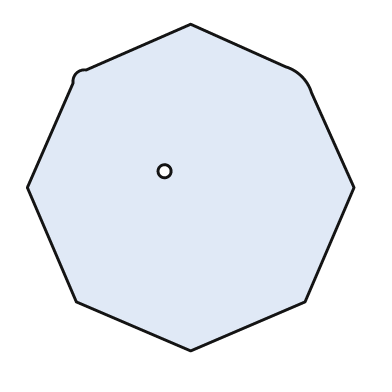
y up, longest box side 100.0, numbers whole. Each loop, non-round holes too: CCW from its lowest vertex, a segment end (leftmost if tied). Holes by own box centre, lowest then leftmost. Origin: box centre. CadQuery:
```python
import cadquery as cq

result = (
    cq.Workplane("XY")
    .moveTo(0.0, -50.0)
    .lineTo(35.0, -35.0)
    .lineTo(50.0, 0.0)
    .lineTo(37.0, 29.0)
    .threePointArc((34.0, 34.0), (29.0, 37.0))
    .lineTo(0.0, 50.0)
    .lineTo(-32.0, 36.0)
    .threePointArc((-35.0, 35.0), (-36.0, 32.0))
    .lineTo(-50.0, 0.0)
    .lineTo(-35.0, -35.0)
    .close()
    .moveTo(-8.0, 5.0)
    .circle(2.0)
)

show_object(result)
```